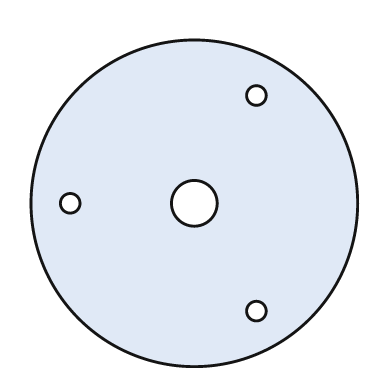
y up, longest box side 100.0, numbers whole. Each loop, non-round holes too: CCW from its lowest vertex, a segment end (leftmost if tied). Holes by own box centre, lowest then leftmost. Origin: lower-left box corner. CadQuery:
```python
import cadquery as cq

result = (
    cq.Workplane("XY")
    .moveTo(50.0, 50.0)
    .circle(50.0)
    .moveTo(69.0, 17.0)
    .circle(3.0)
    .moveTo(12.0, 50.0)
    .circle(3.0)
    .moveTo(50.0, 50.0)
    .circle(7.0)
    .moveTo(69.0, 83.0)
    .circle(3.0)
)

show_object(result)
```